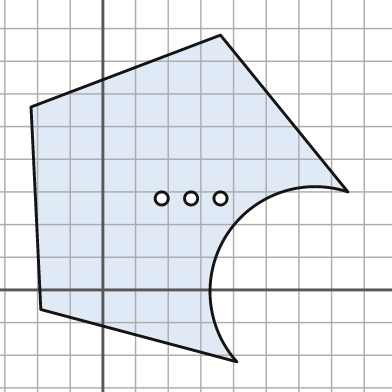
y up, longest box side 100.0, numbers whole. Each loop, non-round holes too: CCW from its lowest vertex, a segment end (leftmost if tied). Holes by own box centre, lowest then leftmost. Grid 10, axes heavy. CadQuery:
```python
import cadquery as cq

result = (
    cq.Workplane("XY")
    .moveTo(41.0, -22.0)
    .threePointArc((38.0, 17.0), (75.0, 30.0))
    .lineTo(36.0, 78.0)
    .lineTo(-22.0, 56.0)
    .lineTo(-19.0, -6.0)
    .close()
    .moveTo(18.0, 28.0)
    .circle(2.0)
    .moveTo(27.0, 28.0)
    .circle(2.0)
    .moveTo(36.0, 28.0)
    .circle(2.0)
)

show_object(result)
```